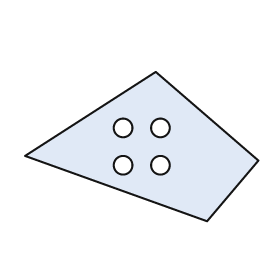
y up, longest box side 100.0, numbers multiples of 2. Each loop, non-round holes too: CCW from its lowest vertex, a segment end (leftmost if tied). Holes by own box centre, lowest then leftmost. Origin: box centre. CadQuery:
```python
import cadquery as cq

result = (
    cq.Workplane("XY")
    .moveTo(28.0, -32.0)
    .lineTo(50.0, -6.0)
    .lineTo(6.0, 32.0)
    .lineTo(-50.0, -4.0)
    .close()
    .moveTo(-8.0, -8.0)
    .circle(4.0)
    .moveTo(8.0, -8.0)
    .circle(4.0)
    .moveTo(-8.0, 8.0)
    .circle(4.0)
    .moveTo(8.0, 8.0)
    .circle(4.0)
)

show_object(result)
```